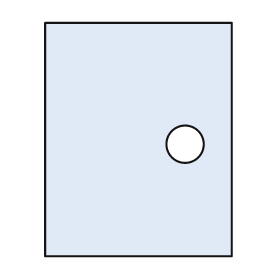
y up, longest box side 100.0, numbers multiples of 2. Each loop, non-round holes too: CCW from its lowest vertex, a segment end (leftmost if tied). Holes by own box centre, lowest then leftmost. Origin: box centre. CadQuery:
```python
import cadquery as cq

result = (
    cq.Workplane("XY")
    .moveTo(-40.0, -50.0)
    .lineTo(40.0, -50.0)
    .lineTo(40.0, 50.0)
    .lineTo(-40.0, 50.0)
    .close()
    .moveTo(20.0, -2.0)
    .circle(8.0)
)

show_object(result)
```